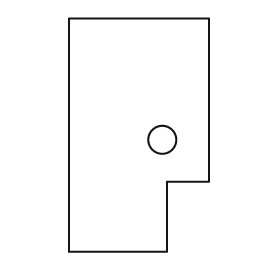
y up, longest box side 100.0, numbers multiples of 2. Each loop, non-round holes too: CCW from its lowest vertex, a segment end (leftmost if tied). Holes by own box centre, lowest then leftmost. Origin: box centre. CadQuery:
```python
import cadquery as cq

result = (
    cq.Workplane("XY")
    .moveTo(-30.0, -50.0)
    .lineTo(12.0, -50.0)
    .lineTo(12.0, -20.0)
    .lineTo(30.0, -20.0)
    .lineTo(30.0, 50.0)
    .lineTo(-30.0, 50.0)
    .close()
    .moveTo(10.0, -2.0)
    .circle(6.0)
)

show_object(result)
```